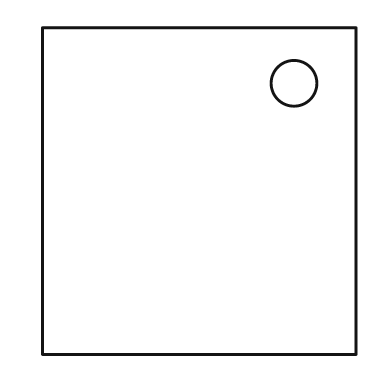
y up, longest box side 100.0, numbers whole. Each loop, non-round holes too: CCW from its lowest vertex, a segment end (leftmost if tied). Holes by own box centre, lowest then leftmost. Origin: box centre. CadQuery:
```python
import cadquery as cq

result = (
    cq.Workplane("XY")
    .moveTo(-48.0, -50.0)
    .lineTo(48.0, -50.0)
    .lineTo(48.0, 50.0)
    .lineTo(-48.0, 50.0)
    .close()
    .moveTo(29.0, 33.0)
    .circle(7.0)
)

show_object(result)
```